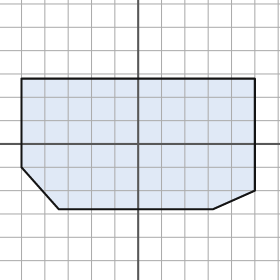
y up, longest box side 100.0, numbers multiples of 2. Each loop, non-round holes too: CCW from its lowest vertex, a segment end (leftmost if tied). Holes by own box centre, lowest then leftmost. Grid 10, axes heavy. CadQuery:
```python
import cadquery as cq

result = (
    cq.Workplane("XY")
    .moveTo(-34.0, -28.0)
    .lineTo(32.0, -28.0)
    .lineTo(50.0, -20.0)
    .lineTo(50.0, 28.0)
    .lineTo(-50.0, 28.0)
    .lineTo(-50.0, -10.0)
    .close()
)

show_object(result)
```